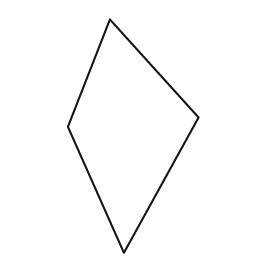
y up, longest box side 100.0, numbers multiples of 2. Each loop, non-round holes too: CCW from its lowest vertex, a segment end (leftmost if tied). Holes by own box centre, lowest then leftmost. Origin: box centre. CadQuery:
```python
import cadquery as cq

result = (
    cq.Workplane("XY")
    .moveTo(-4.0, -50.0)
    .lineTo(28.0, 8.0)
    .lineTo(-10.0, 50.0)
    .lineTo(-28.0, 4.0)
    .close()
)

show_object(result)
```